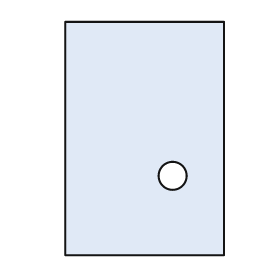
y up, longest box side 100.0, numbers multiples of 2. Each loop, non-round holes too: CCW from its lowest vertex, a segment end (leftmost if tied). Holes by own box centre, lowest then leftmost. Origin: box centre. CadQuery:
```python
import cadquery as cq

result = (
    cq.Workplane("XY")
    .moveTo(-34.0, -50.0)
    .lineTo(34.0, -50.0)
    .lineTo(34.0, 50.0)
    .lineTo(-34.0, 50.0)
    .close()
    .moveTo(12.0, -16.0)
    .circle(6.0)
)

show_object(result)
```